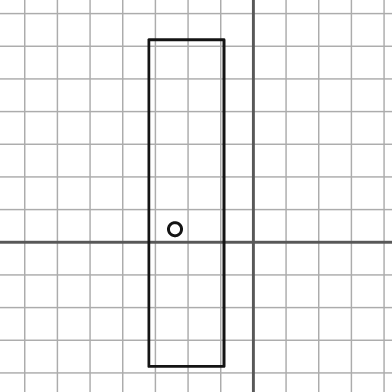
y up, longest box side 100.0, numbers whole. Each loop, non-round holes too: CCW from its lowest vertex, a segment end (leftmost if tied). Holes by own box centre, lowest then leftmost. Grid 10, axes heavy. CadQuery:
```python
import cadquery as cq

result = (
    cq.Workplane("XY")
    .moveTo(-32.0, -38.0)
    .lineTo(-9.0, -38.0)
    .lineTo(-9.0, 62.0)
    .lineTo(-32.0, 62.0)
    .close()
    .moveTo(-24.0, 4.0)
    .circle(2.0)
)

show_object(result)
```